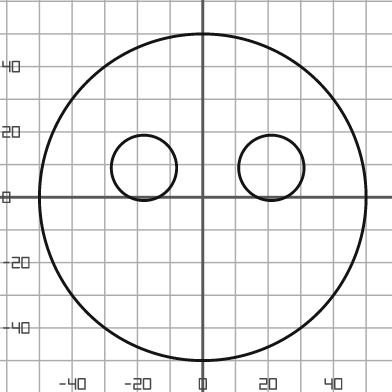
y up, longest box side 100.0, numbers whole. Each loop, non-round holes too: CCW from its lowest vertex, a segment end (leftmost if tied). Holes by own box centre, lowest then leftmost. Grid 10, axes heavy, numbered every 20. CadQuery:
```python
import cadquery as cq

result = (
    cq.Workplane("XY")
    .moveTo(0.0, 0.0)
    .circle(50.0)
    .moveTo(-18.0, 9.0)
    .circle(10.0)
    .moveTo(21.0, 9.0)
    .circle(10.0)
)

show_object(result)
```